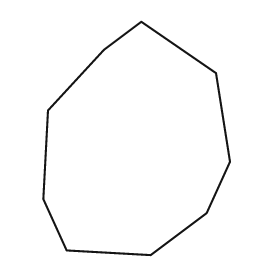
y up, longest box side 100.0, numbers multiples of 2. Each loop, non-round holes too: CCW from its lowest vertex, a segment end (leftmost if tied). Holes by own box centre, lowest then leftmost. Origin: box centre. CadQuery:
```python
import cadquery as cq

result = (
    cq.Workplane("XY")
    .moveTo(6.0, -50.0)
    .lineTo(30.0, -32.0)
    .lineTo(40.0, -10.0)
    .lineTo(34.0, 28.0)
    .lineTo(2.0, 50.0)
    .lineTo(-14.0, 38.0)
    .lineTo(-38.0, 12.0)
    .lineTo(-40.0, -26.0)
    .lineTo(-30.0, -48.0)
    .close()
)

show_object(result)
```